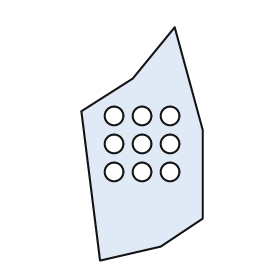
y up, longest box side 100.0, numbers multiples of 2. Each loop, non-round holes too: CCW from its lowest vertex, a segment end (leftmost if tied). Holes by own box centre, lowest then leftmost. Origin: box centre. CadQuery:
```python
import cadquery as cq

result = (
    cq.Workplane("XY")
    .moveTo(-18.0, -50.0)
    .lineTo(8.0, -44.0)
    .lineTo(26.0, -32.0)
    .lineTo(26.0, 6.0)
    .lineTo(14.0, 50.0)
    .lineTo(-4.0, 28.0)
    .lineTo(-26.0, 14.0)
    .close()
    .moveTo(-12.0, -12.0)
    .circle(4.0)
    .moveTo(0.0, -12.0)
    .circle(4.0)
    .moveTo(12.0, -12.0)
    .circle(4.0)
    .moveTo(-12.0, 0.0)
    .circle(4.0)
    .moveTo(0.0, 0.0)
    .circle(4.0)
    .moveTo(12.0, 0.0)
    .circle(4.0)
    .moveTo(-12.0, 12.0)
    .circle(4.0)
    .moveTo(0.0, 12.0)
    .circle(4.0)
    .moveTo(12.0, 12.0)
    .circle(4.0)
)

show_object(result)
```